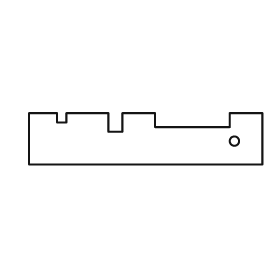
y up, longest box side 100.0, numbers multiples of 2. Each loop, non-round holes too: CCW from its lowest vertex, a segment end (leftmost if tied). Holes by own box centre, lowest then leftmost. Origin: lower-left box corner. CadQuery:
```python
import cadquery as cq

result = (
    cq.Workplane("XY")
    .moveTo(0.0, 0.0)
    .lineTo(100.0, 0.0)
    .lineTo(100.0, 22.0)
    .lineTo(86.0, 22.0)
    .lineTo(86.0, 16.0)
    .lineTo(54.0, 16.0)
    .lineTo(54.0, 22.0)
    .lineTo(40.0, 22.0)
    .lineTo(40.0, 14.0)
    .lineTo(34.0, 14.0)
    .lineTo(34.0, 22.0)
    .lineTo(16.0, 22.0)
    .lineTo(16.0, 18.0)
    .lineTo(12.0, 18.0)
    .lineTo(12.0, 22.0)
    .lineTo(0.0, 22.0)
    .close()
    .moveTo(88.0, 10.0)
    .circle(2.0)
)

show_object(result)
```